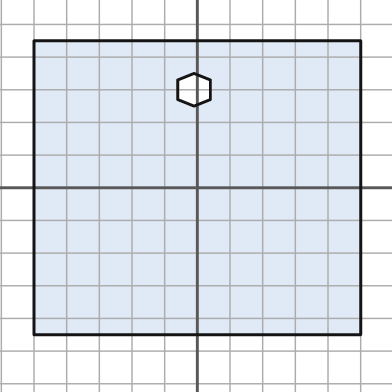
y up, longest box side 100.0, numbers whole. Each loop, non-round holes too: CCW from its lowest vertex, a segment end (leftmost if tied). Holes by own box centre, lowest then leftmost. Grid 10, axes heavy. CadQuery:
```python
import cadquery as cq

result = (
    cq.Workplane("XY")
    .moveTo(-50.0, -45.0)
    .lineTo(50.0, -45.0)
    .lineTo(50.0, 45.0)
    .lineTo(-50.0, 45.0)
    .close()
    .moveTo(-1.0, 25.0)
    .lineTo(4.0, 27.0)
    .lineTo(4.0, 33.0)
    .lineTo(-1.0, 35.0)
    .lineTo(-6.0, 33.0)
    .lineTo(-6.0, 27.0)
    .close()
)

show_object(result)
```